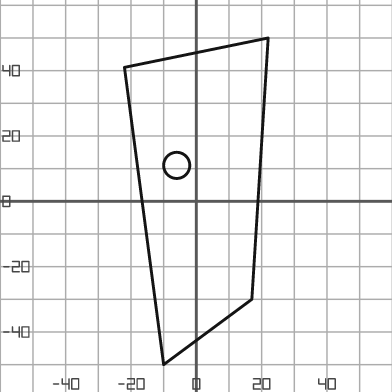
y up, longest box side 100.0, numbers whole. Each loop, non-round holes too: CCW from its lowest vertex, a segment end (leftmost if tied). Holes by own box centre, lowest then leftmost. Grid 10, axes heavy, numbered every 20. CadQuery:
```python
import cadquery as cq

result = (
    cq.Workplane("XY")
    .moveTo(-10.0, -50.0)
    .lineTo(17.0, -30.0)
    .lineTo(22.0, 50.0)
    .lineTo(-22.0, 41.0)
    .close()
    .moveTo(-6.0, 11.0)
    .circle(4.0)
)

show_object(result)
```